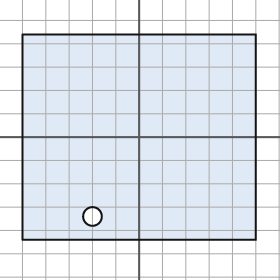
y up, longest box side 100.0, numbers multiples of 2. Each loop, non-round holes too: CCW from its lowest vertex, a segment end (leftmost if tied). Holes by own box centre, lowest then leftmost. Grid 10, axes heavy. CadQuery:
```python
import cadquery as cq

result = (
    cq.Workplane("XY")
    .moveTo(-50.0, -44.0)
    .lineTo(50.0, -44.0)
    .lineTo(50.0, 44.0)
    .lineTo(-50.0, 44.0)
    .close()
    .moveTo(-20.0, -34.0)
    .circle(4.0)
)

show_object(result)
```